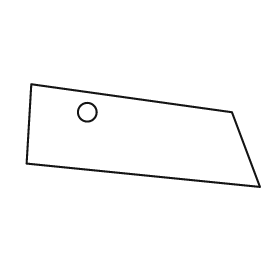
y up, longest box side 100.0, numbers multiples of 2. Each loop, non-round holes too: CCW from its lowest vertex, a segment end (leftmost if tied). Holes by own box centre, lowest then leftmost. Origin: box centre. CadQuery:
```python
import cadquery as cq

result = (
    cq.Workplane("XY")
    .moveTo(50.0, -22.0)
    .lineTo(38.0, 10.0)
    .lineTo(-48.0, 22.0)
    .lineTo(-50.0, -12.0)
    .close()
    .moveTo(-24.0, 10.0)
    .circle(4.0)
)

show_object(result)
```